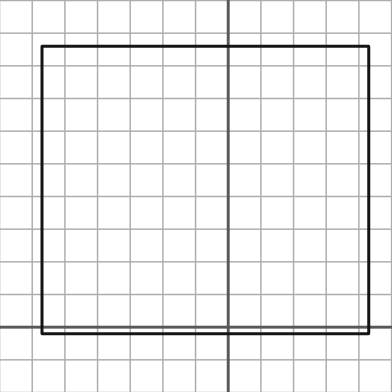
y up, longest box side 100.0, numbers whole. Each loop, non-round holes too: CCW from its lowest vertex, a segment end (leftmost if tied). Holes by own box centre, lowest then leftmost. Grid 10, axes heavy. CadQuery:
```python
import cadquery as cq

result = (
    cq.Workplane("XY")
    .moveTo(-57.0, -2.0)
    .lineTo(43.0, -2.0)
    .lineTo(43.0, 86.0)
    .lineTo(-57.0, 86.0)
    .close()
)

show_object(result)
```